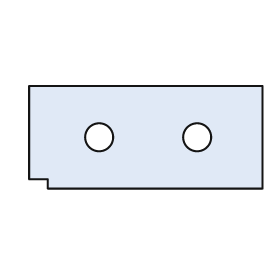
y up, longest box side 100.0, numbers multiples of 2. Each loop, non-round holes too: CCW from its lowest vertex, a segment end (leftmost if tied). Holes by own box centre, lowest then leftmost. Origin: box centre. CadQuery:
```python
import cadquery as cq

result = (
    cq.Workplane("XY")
    .moveTo(-42.0, -22.0)
    .lineTo(50.0, -22.0)
    .lineTo(50.0, 22.0)
    .lineTo(-50.0, 22.0)
    .lineTo(-50.0, -18.0)
    .lineTo(-42.0, -18.0)
    .close()
    .moveTo(-20.0, 0.0)
    .circle(6.0)
    .moveTo(22.0, 0.0)
    .circle(6.0)
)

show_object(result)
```